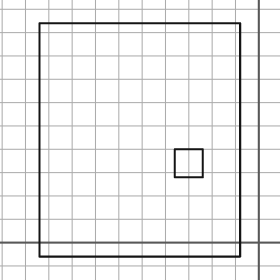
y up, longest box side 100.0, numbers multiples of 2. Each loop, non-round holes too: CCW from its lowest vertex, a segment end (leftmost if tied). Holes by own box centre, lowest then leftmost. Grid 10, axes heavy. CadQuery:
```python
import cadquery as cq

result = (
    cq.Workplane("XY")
    .moveTo(-94.0, -6.0)
    .lineTo(-8.0, -6.0)
    .lineTo(-8.0, 94.0)
    .lineTo(-94.0, 94.0)
    .close()
    .moveTo(-36.0, 28.0)
    .lineTo(-24.0, 28.0)
    .lineTo(-24.0, 40.0)
    .lineTo(-36.0, 40.0)
    .close()
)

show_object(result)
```